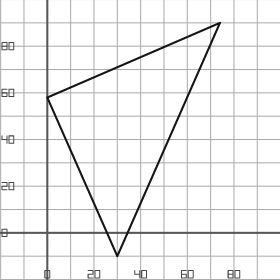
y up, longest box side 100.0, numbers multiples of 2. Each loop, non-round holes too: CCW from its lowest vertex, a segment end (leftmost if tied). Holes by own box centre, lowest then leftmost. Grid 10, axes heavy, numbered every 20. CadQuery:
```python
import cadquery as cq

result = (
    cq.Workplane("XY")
    .moveTo(30.0, -10.0)
    .lineTo(74.0, 90.0)
    .lineTo(0.0, 58.0)
    .close()
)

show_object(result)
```